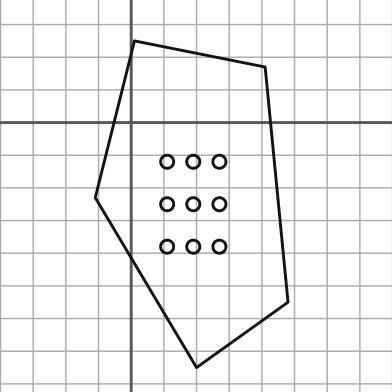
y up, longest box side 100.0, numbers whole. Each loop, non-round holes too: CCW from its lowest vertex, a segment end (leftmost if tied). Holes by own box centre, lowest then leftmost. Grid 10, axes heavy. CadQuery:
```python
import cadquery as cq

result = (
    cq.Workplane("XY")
    .moveTo(20.0, -75.0)
    .lineTo(48.0, -55.0)
    .lineTo(41.0, 17.0)
    .lineTo(1.0, 25.0)
    .lineTo(-11.0, -23.0)
    .close()
    .moveTo(11.0, -38.0)
    .circle(2.0)
    .moveTo(19.0, -38.0)
    .circle(2.0)
    .moveTo(27.0, -38.0)
    .circle(2.0)
    .moveTo(11.0, -25.0)
    .circle(2.0)
    .moveTo(19.0, -25.0)
    .circle(2.0)
    .moveTo(27.0, -25.0)
    .circle(2.0)
    .moveTo(11.0, -12.0)
    .circle(2.0)
    .moveTo(19.0, -12.0)
    .circle(2.0)
    .moveTo(27.0, -12.0)
    .circle(2.0)
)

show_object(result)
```